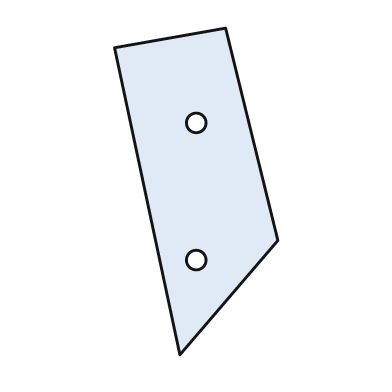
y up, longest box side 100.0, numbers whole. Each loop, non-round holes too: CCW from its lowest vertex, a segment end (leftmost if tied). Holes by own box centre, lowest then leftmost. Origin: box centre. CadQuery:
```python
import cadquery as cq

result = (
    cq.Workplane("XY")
    .moveTo(-5.0, -50.0)
    .lineTo(25.0, -15.0)
    .lineTo(9.0, 50.0)
    .lineTo(-25.0, 44.0)
    .close()
    .moveTo(0.0, -21.0)
    .circle(3.0)
    .moveTo(0.0, 21.0)
    .circle(3.0)
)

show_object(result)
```